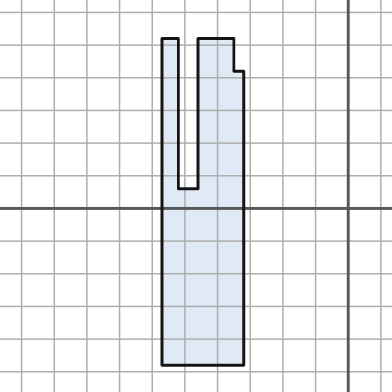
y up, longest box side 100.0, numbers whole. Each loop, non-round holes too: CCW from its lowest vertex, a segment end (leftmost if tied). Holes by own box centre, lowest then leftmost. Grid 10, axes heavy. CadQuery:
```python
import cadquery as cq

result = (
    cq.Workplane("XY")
    .moveTo(-57.0, -48.0)
    .lineTo(-32.0, -48.0)
    .lineTo(-32.0, 42.0)
    .lineTo(-35.0, 42.0)
    .lineTo(-35.0, 52.0)
    .lineTo(-46.0, 52.0)
    .lineTo(-46.0, 6.0)
    .lineTo(-52.0, 6.0)
    .lineTo(-52.0, 52.0)
    .lineTo(-57.0, 52.0)
    .close()
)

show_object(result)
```